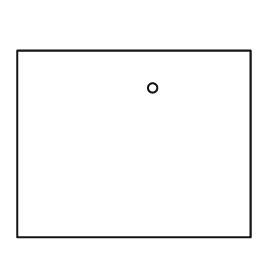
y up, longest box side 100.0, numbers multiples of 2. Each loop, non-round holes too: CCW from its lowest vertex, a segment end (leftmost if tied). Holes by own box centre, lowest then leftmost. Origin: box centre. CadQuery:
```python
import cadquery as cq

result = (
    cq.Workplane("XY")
    .moveTo(-50.0, -40.0)
    .lineTo(50.0, -40.0)
    .lineTo(50.0, 40.0)
    .lineTo(-50.0, 40.0)
    .close()
    .moveTo(8.0, 24.0)
    .circle(2.0)
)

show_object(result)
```